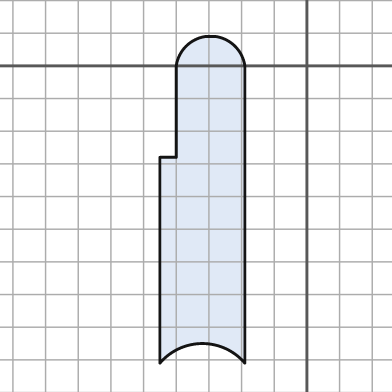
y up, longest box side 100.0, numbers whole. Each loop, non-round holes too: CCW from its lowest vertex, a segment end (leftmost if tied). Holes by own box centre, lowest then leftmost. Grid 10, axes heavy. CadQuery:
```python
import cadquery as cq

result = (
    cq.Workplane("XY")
    .moveTo(-45.0, -91.0)
    .threePointArc((-32.0, -85.0), (-19.0, -91.0))
    .lineTo(-19.0, 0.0)
    .threePointArc((-22.0, 6.0), (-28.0, 9.0))
    .lineTo(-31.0, 9.0)
    .threePointArc((-37.0, 6.0), (-40.0, 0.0))
    .lineTo(-40.0, -28.0)
    .lineTo(-45.0, -28.0)
    .close()
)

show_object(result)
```